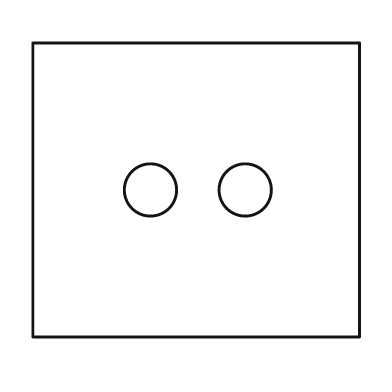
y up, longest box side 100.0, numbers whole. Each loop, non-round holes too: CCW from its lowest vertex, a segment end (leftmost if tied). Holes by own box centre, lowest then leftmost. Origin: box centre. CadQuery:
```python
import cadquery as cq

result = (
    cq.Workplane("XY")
    .moveTo(-50.0, -45.0)
    .lineTo(50.0, -45.0)
    .lineTo(50.0, 45.0)
    .lineTo(-50.0, 45.0)
    .close()
    .moveTo(-14.0, 0.0)
    .circle(8.0)
    .moveTo(15.0, 0.0)
    .circle(8.0)
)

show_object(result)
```